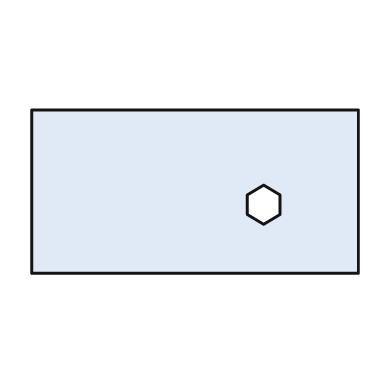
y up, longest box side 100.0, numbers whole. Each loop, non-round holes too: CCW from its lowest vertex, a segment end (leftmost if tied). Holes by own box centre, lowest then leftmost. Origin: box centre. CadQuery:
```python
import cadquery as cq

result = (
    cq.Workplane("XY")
    .moveTo(-50.0, -25.0)
    .lineTo(50.0, -25.0)
    .lineTo(50.0, 25.0)
    .lineTo(-50.0, 25.0)
    .close()
    .moveTo(21.0, -10.0)
    .lineTo(26.0, -7.0)
    .lineTo(26.0, -1.0)
    .lineTo(21.0, 2.0)
    .lineTo(16.0, -1.0)
    .lineTo(16.0, -7.0)
    .close()
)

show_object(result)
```